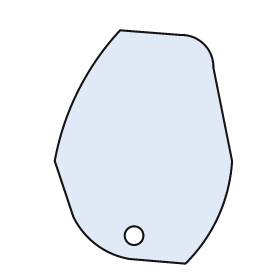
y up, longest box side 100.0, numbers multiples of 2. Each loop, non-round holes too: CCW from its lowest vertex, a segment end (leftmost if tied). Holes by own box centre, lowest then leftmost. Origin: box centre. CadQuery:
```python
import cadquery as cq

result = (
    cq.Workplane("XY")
    .moveTo(18.0, -50.0)
    .threePointArc((32.0, -30.0), (38.0, -6.0))
    .lineTo(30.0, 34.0)
    .threePointArc((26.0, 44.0), (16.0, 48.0))
    .lineTo(-10.0, 50.0)
    .threePointArc((-28.0, 24.0), (-38.0, -6.0))
    .lineTo(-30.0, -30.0)
    .threePointArc((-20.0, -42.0), (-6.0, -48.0))
    .close()
    .moveTo(-4.0, -38.0)
    .circle(4.0)
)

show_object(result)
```